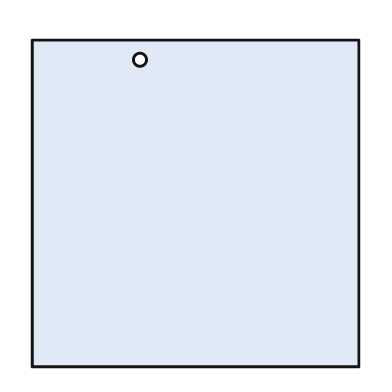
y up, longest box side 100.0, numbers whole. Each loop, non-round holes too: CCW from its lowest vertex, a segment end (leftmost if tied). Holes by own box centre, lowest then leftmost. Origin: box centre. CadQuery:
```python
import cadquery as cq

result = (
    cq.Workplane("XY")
    .moveTo(-50.0, -50.0)
    .lineTo(50.0, -50.0)
    .lineTo(50.0, 50.0)
    .lineTo(-50.0, 50.0)
    .close()
    .moveTo(-17.0, 44.0)
    .circle(2.0)
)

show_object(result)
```